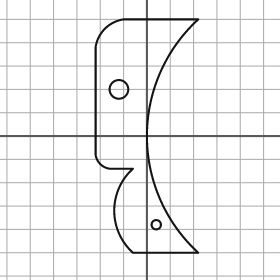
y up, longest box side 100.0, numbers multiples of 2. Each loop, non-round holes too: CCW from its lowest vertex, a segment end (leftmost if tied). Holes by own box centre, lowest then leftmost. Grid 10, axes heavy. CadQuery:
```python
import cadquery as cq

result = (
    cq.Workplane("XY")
    .moveTo(-6.0, -50.0)
    .lineTo(22.0, -50.0)
    .threePointArc((0.0, 0.0), (22.0, 50.0))
    .lineTo(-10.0, 50.0)
    .threePointArc((-18.0, 46.0), (-22.0, 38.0))
    .lineTo(-22.0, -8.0)
    .threePointArc((-20.0, -12.0), (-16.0, -14.0))
    .lineTo(-6.0, -14.0)
    .threePointArc((-14.0, -32.0), (-6.0, -50.0))
    .close()
    .moveTo(4.0, -38.0)
    .circle(2.0)
    .moveTo(-12.0, 20.0)
    .circle(4.0)
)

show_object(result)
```